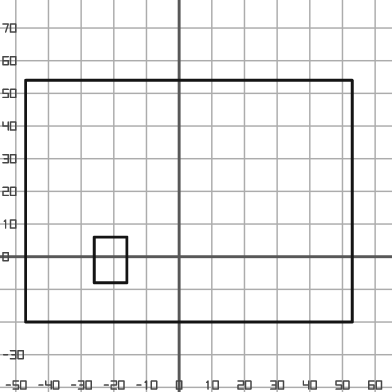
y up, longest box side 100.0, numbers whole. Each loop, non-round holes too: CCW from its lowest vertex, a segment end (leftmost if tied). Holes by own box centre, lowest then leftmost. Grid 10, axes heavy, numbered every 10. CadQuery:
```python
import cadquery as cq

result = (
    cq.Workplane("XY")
    .moveTo(-47.0, -20.0)
    .lineTo(53.0, -20.0)
    .lineTo(53.0, 54.0)
    .lineTo(-47.0, 54.0)
    .close()
    .moveTo(-26.0, -8.0)
    .lineTo(-16.0, -8.0)
    .lineTo(-16.0, 6.0)
    .lineTo(-26.0, 6.0)
    .close()
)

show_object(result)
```